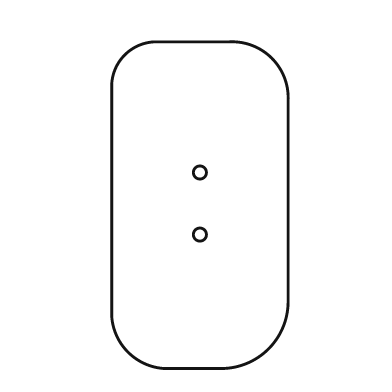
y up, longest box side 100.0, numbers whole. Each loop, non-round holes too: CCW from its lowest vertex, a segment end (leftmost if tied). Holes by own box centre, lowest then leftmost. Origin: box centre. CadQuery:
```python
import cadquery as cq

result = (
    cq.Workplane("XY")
    .moveTo(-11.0, -50.0)
    .lineTo(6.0, -50.0)
    .threePointArc((21.0, -44.0), (27.0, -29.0))
    .lineTo(27.0, 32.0)
    .threePointArc((22.0, 45.0), (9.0, 50.0))
    .lineTo(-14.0, 50.0)
    .threePointArc((-23.0, 46.0), (-27.0, 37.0))
    .lineTo(-27.0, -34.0)
    .threePointArc((-22.0, -45.0), (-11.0, -50.0))
    .close()
    .moveTo(0.0, -9.0)
    .circle(2.0)
    .moveTo(0.0, 10.0)
    .circle(2.0)
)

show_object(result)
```